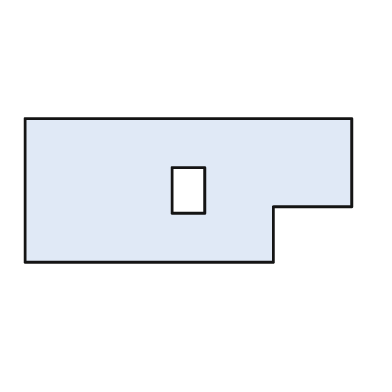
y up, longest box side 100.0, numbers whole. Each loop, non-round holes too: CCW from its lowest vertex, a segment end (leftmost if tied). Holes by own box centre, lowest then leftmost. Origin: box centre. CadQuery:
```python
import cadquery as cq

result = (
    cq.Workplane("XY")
    .moveTo(-50.0, -22.0)
    .lineTo(26.0, -22.0)
    .lineTo(26.0, -5.0)
    .lineTo(50.0, -5.0)
    .lineTo(50.0, 22.0)
    .lineTo(-50.0, 22.0)
    .close()
    .moveTo(-5.0, -7.0)
    .lineTo(5.0, -7.0)
    .lineTo(5.0, 7.0)
    .lineTo(-5.0, 7.0)
    .close()
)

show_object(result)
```